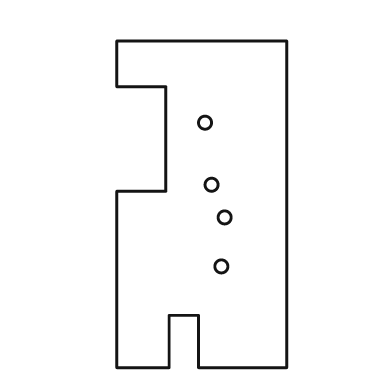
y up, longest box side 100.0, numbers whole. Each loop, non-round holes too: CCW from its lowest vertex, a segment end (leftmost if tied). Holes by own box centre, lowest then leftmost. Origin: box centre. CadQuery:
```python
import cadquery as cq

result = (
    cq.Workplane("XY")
    .moveTo(-26.0, -50.0)
    .lineTo(-10.0, -50.0)
    .lineTo(-10.0, -34.0)
    .lineTo(-1.0, -34.0)
    .lineTo(-1.0, -50.0)
    .lineTo(26.0, -50.0)
    .lineTo(26.0, 50.0)
    .lineTo(-26.0, 50.0)
    .lineTo(-26.0, 36.0)
    .lineTo(-11.0, 36.0)
    .lineTo(-11.0, 4.0)
    .lineTo(-26.0, 4.0)
    .close()
    .moveTo(6.0, -19.0)
    .circle(2.0)
    .moveTo(7.0, -4.0)
    .circle(2.0)
    .moveTo(3.0, 6.0)
    .circle(2.0)
    .moveTo(1.0, 25.0)
    .circle(2.0)
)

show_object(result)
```